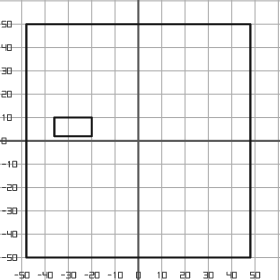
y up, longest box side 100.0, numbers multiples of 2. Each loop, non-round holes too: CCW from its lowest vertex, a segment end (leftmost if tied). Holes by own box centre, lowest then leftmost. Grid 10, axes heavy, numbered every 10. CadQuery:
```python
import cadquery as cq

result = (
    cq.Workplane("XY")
    .moveTo(-48.0, -50.0)
    .lineTo(48.0, -50.0)
    .lineTo(48.0, 50.0)
    .lineTo(-48.0, 50.0)
    .close()
    .moveTo(-36.0, 2.0)
    .lineTo(-20.0, 2.0)
    .lineTo(-20.0, 10.0)
    .lineTo(-36.0, 10.0)
    .close()
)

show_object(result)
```